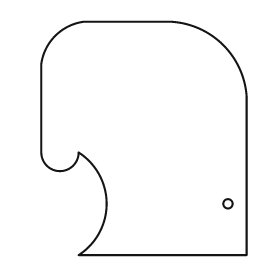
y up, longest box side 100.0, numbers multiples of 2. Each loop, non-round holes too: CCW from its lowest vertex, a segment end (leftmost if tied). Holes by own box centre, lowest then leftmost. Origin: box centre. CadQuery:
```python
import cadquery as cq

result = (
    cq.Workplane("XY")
    .moveTo(-28.0, -50.0)
    .lineTo(44.0, -50.0)
    .lineTo(44.0, 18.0)
    .threePointArc((34.0, 40.0), (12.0, 50.0))
    .lineTo(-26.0, 50.0)
    .threePointArc((-38.0, 44.0), (-44.0, 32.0))
    .lineTo(-44.0, -6.0)
    .threePointArc((-36.0, -14.0), (-28.0, -6.0))
    .threePointArc((-16.0, -28.0), (-28.0, -50.0))
    .close()
    .moveTo(36.0, -28.0)
    .circle(2.0)
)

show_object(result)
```